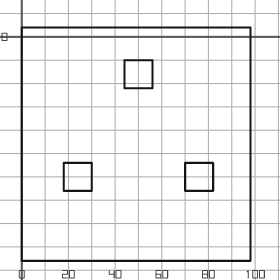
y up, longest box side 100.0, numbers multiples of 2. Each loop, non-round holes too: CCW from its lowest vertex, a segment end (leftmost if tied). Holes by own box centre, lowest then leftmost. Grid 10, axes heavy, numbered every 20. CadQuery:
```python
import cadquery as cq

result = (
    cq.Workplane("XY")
    .moveTo(0.0, -96.0)
    .lineTo(98.0, -96.0)
    .lineTo(98.0, 4.0)
    .lineTo(0.0, 4.0)
    .close()
    .moveTo(18.0, -66.0)
    .lineTo(30.0, -66.0)
    .lineTo(30.0, -54.0)
    .lineTo(18.0, -54.0)
    .close()
    .moveTo(70.0, -66.0)
    .lineTo(82.0, -66.0)
    .lineTo(82.0, -54.0)
    .lineTo(70.0, -54.0)
    .close()
    .moveTo(44.0, -22.0)
    .lineTo(56.0, -22.0)
    .lineTo(56.0, -10.0)
    .lineTo(44.0, -10.0)
    .close()
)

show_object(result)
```